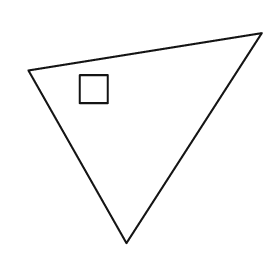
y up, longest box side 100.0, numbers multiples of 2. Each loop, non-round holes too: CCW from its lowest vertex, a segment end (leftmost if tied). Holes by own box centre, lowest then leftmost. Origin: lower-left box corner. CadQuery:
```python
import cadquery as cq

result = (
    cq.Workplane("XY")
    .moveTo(42.0, 0.0)
    .lineTo(100.0, 90.0)
    .lineTo(0.0, 74.0)
    .close()
    .moveTo(22.0, 60.0)
    .lineTo(34.0, 60.0)
    .lineTo(34.0, 72.0)
    .lineTo(22.0, 72.0)
    .close()
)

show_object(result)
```